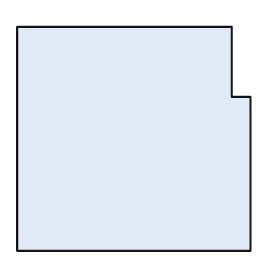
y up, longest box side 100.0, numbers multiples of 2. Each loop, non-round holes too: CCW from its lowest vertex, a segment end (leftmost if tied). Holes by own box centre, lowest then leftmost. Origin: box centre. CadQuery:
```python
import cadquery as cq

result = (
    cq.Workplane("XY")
    .moveTo(-50.0, -48.0)
    .lineTo(50.0, -48.0)
    .lineTo(50.0, 18.0)
    .lineTo(42.0, 18.0)
    .lineTo(42.0, 48.0)
    .lineTo(-50.0, 48.0)
    .close()
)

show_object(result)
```